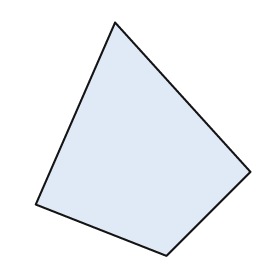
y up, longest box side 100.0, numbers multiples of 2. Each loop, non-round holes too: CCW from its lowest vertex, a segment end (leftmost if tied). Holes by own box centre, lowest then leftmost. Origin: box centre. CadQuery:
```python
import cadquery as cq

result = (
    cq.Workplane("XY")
    .moveTo(10.0, -50.0)
    .lineTo(46.0, -14.0)
    .lineTo(-12.0, 50.0)
    .lineTo(-46.0, -28.0)
    .close()
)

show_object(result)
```